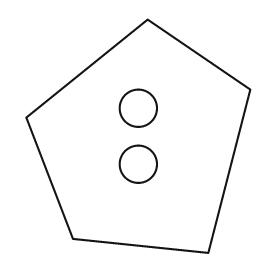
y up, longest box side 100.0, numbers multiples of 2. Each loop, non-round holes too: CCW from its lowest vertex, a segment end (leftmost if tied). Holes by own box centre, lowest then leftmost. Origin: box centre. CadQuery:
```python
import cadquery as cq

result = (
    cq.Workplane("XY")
    .moveTo(30.0, -50.0)
    .lineTo(48.0, 20.0)
    .lineTo(4.0, 50.0)
    .lineTo(-48.0, 8.0)
    .lineTo(-28.0, -44.0)
    .close()
    .moveTo(0.0, -12.0)
    .circle(8.0)
    .moveTo(0.0, 12.0)
    .circle(8.0)
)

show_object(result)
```